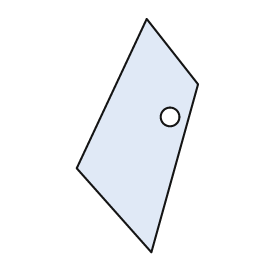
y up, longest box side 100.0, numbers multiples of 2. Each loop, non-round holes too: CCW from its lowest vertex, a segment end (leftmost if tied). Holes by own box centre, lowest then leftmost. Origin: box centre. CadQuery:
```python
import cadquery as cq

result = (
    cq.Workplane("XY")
    .moveTo(6.0, -50.0)
    .lineTo(26.0, 22.0)
    .lineTo(4.0, 50.0)
    .lineTo(-26.0, -14.0)
    .close()
    .moveTo(14.0, 8.0)
    .circle(4.0)
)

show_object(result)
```